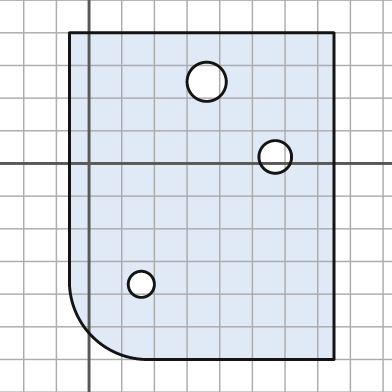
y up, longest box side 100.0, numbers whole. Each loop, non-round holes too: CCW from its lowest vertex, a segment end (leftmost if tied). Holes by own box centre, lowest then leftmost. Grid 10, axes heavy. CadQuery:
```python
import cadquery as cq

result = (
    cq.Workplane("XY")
    .moveTo(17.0, -60.0)
    .lineTo(75.0, -60.0)
    .lineTo(75.0, 40.0)
    .lineTo(-6.0, 40.0)
    .lineTo(-6.0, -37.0)
    .threePointArc((1.0, -53.0), (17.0, -60.0))
    .close()
    .moveTo(16.0, -37.0)
    .circle(4.0)
    .moveTo(57.0, 2.0)
    .circle(5.0)
    .moveTo(36.0, 25.0)
    .circle(6.0)
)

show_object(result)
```